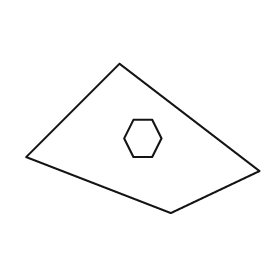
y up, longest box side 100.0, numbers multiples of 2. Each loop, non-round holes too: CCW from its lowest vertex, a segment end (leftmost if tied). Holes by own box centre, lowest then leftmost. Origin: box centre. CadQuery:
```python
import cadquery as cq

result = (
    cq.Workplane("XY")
    .moveTo(12.0, -32.0)
    .lineTo(50.0, -14.0)
    .lineTo(-10.0, 32.0)
    .lineTo(-50.0, -8.0)
    .close()
    .moveTo(-4.0, -8.0)
    .lineTo(4.0, -8.0)
    .lineTo(8.0, 0.0)
    .lineTo(4.0, 8.0)
    .lineTo(-4.0, 8.0)
    .lineTo(-8.0, 0.0)
    .close()
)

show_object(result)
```